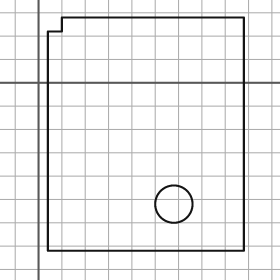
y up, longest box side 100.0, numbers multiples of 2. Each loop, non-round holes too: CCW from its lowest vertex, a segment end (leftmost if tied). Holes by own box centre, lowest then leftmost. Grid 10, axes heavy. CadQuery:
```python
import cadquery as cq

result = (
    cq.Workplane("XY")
    .moveTo(4.0, -72.0)
    .lineTo(88.0, -72.0)
    .lineTo(88.0, 28.0)
    .lineTo(10.0, 28.0)
    .lineTo(10.0, 22.0)
    .lineTo(4.0, 22.0)
    .close()
    .moveTo(58.0, -52.0)
    .circle(8.0)
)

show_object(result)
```